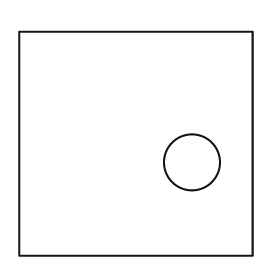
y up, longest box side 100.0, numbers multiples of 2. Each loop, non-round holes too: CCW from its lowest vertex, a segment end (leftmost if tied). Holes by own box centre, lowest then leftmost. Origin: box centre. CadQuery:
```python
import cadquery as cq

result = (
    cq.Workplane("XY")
    .moveTo(-50.0, -48.0)
    .lineTo(50.0, -48.0)
    .lineTo(50.0, 48.0)
    .lineTo(-50.0, 48.0)
    .close()
    .moveTo(24.0, -8.0)
    .circle(12.0)
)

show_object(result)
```